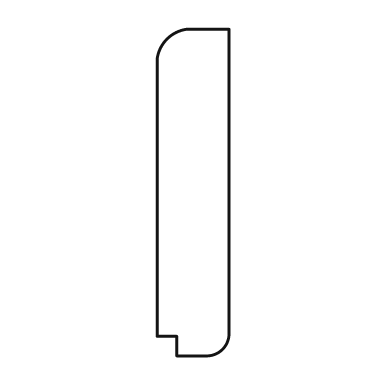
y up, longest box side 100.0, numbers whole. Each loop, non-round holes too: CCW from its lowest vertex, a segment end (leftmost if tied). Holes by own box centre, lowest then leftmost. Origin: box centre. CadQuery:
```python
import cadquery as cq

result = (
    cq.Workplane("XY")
    .moveTo(-5.0, -50.0)
    .lineTo(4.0, -50.0)
    .threePointArc((9.0, -48.0), (11.0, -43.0))
    .lineTo(11.0, 50.0)
    .lineTo(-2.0, 50.0)
    .threePointArc((-8.0, 47.0), (-11.0, 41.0))
    .lineTo(-11.0, -44.0)
    .lineTo(-5.0, -44.0)
    .close()
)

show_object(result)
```